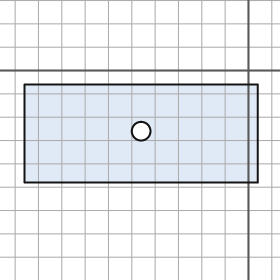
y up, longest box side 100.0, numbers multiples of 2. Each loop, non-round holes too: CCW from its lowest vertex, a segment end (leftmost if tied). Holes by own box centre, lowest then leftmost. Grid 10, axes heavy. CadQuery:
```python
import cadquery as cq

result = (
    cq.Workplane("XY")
    .moveTo(-96.0, -48.0)
    .lineTo(4.0, -48.0)
    .lineTo(4.0, -6.0)
    .lineTo(-96.0, -6.0)
    .close()
    .moveTo(-46.0, -26.0)
    .circle(4.0)
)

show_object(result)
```